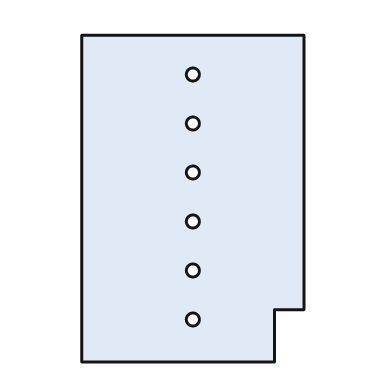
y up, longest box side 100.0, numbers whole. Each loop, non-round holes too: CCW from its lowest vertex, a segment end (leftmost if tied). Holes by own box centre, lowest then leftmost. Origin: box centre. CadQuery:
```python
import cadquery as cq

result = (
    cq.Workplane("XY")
    .moveTo(-34.0, -50.0)
    .lineTo(25.0, -50.0)
    .lineTo(25.0, -34.0)
    .lineTo(34.0, -34.0)
    .lineTo(34.0, 50.0)
    .lineTo(-34.0, 50.0)
    .close()
    .moveTo(0.0, -37.0)
    .circle(2.0)
    .moveTo(0.0, -22.0)
    .circle(2.0)
    .moveTo(0.0, -7.0)
    .circle(2.0)
    .moveTo(0.0, 8.0)
    .circle(2.0)
    .moveTo(0.0, 23.0)
    .circle(2.0)
    .moveTo(0.0, 38.0)
    .circle(2.0)
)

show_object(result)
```